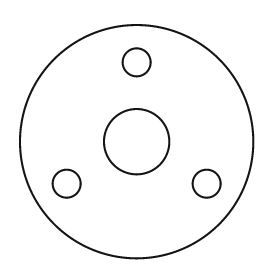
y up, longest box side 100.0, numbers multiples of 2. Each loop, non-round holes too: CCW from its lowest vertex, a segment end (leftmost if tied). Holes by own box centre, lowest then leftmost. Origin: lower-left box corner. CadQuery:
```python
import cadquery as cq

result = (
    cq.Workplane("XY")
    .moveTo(50.0, 50.0)
    .circle(50.0)
    .moveTo(20.0, 32.0)
    .circle(6.0)
    .moveTo(80.0, 32.0)
    .circle(6.0)
    .moveTo(50.0, 50.0)
    .circle(14.0)
    .moveTo(50.0, 84.0)
    .circle(6.0)
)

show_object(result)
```